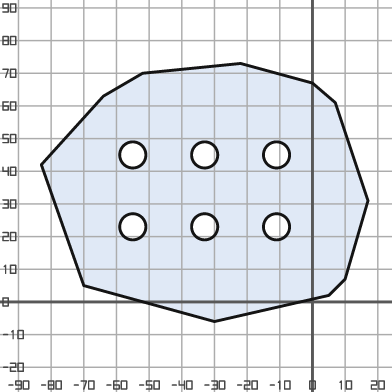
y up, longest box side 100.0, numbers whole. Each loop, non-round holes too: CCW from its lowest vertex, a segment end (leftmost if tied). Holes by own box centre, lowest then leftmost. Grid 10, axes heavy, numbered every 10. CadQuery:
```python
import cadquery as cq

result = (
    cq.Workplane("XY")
    .moveTo(-30.0, -6.0)
    .lineTo(5.0, 2.0)
    .lineTo(10.0, 7.0)
    .lineTo(17.0, 31.0)
    .lineTo(7.0, 61.0)
    .lineTo(0.0, 67.0)
    .lineTo(-22.0, 73.0)
    .lineTo(-52.0, 70.0)
    .lineTo(-64.0, 63.0)
    .lineTo(-83.0, 42.0)
    .lineTo(-70.0, 5.0)
    .close()
    .moveTo(-55.0, 23.0)
    .circle(4.0)
    .moveTo(-33.0, 23.0)
    .circle(4.0)
    .moveTo(-11.0, 23.0)
    .circle(4.0)
    .moveTo(-55.0, 45.0)
    .circle(4.0)
    .moveTo(-33.0, 45.0)
    .circle(4.0)
    .moveTo(-11.0, 45.0)
    .circle(4.0)
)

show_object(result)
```